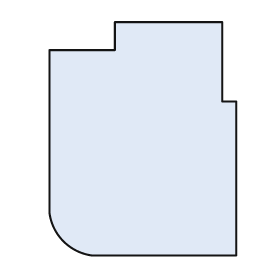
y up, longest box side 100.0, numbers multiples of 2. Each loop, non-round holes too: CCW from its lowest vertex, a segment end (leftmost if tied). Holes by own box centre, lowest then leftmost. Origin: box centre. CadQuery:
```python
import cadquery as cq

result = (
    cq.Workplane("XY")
    .moveTo(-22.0, -50.0)
    .lineTo(40.0, -50.0)
    .lineTo(40.0, 16.0)
    .lineTo(34.0, 16.0)
    .lineTo(34.0, 50.0)
    .lineTo(-12.0, 50.0)
    .lineTo(-12.0, 38.0)
    .lineTo(-40.0, 38.0)
    .lineTo(-40.0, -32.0)
    .threePointArc((-34.0, -44.0), (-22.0, -50.0))
    .close()
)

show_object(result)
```